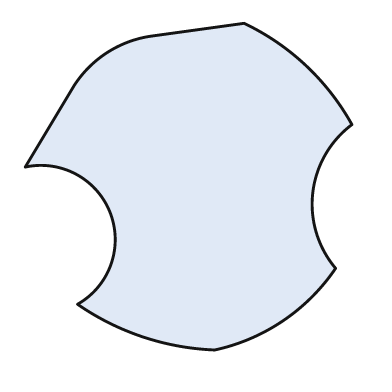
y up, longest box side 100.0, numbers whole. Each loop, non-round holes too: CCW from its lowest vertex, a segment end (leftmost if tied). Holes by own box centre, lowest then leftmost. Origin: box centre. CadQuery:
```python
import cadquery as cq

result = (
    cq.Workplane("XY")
    .moveTo(8.0, -50.0)
    .threePointArc((29.0, -41.0), (45.0, -25.0))
    .threePointArc((38.0, -2.0), (50.0, 19.0))
    .threePointArc((36.0, 37.0), (17.0, 50.0))
    .lineTo(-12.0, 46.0)
    .threePointArc((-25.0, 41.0), (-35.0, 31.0))
    .lineTo(-50.0, 6.0)
    .threePointArc((-24.0, -8.0), (-34.0, -36.0))
    .threePointArc((-14.0, -46.0), (8.0, -50.0))
    .close()
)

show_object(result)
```